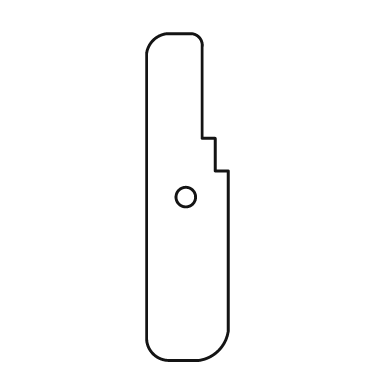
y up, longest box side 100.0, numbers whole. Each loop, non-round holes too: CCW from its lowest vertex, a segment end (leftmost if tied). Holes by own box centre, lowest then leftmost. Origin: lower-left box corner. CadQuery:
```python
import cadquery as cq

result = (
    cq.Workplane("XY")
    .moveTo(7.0, 0.0)
    .lineTo(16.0, 0.0)
    .threePointArc((22.0, 3.0), (25.0, 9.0))
    .lineTo(25.0, 58.0)
    .lineTo(21.0, 58.0)
    .lineTo(21.0, 68.0)
    .lineTo(17.0, 68.0)
    .lineTo(17.0, 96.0)
    .threePointArc((16.0, 99.0), (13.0, 100.0))
    .lineTo(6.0, 100.0)
    .threePointArc((2.0, 98.0), (0.0, 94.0))
    .lineTo(0.0, 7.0)
    .threePointArc((2.0, 2.0), (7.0, 0.0))
    .close()
    .moveTo(12.0, 50.0)
    .circle(3.0)
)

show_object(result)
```